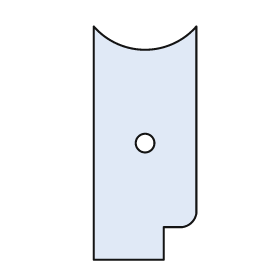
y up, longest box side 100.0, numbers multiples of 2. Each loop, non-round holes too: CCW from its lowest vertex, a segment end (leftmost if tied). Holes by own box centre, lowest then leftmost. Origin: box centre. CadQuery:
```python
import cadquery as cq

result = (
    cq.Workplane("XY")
    .moveTo(-22.0, -50.0)
    .lineTo(8.0, -50.0)
    .lineTo(8.0, -36.0)
    .lineTo(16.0, -36.0)
    .threePointArc((20.0, -34.0), (22.0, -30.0))
    .lineTo(22.0, 50.0)
    .threePointArc((0.0, 40.0), (-22.0, 50.0))
    .close()
    .moveTo(0.0, 0.0)
    .circle(4.0)
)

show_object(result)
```